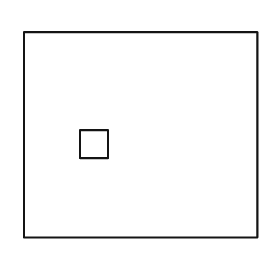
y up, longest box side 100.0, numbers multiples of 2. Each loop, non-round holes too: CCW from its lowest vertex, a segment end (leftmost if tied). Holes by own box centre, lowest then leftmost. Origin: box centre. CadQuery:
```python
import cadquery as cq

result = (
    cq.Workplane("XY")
    .moveTo(-50.0, -44.0)
    .lineTo(50.0, -44.0)
    .lineTo(50.0, 44.0)
    .lineTo(-50.0, 44.0)
    .close()
    .moveTo(-26.0, -10.0)
    .lineTo(-14.0, -10.0)
    .lineTo(-14.0, 2.0)
    .lineTo(-26.0, 2.0)
    .close()
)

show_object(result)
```